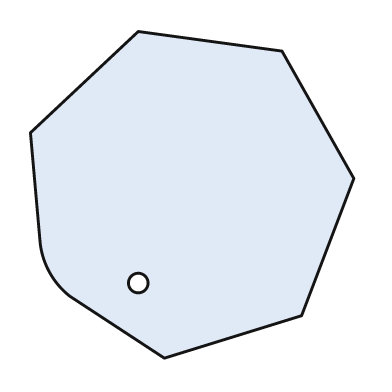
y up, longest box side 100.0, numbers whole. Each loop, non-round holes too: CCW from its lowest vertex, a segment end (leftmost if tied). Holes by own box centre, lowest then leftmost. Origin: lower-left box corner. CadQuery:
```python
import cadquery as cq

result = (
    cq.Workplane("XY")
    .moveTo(41.0, 0.0)
    .lineTo(83.0, 13.0)
    .lineTo(99.0, 55.0)
    .lineTo(77.0, 94.0)
    .lineTo(33.0, 100.0)
    .lineTo(0.0, 69.0)
    .lineTo(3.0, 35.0)
    .threePointArc((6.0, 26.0), (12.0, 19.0))
    .close()
    .moveTo(33.0, 23.0)
    .circle(3.0)
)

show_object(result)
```